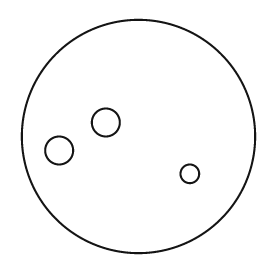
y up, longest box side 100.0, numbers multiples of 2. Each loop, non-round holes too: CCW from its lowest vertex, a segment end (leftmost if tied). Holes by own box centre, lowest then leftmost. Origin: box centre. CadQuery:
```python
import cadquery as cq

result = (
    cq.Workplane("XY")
    .moveTo(0.0, 0.0)
    .circle(50.0)
    .moveTo(22.0, -16.0)
    .circle(4.0)
    .moveTo(-34.0, -6.0)
    .circle(6.0)
    .moveTo(-14.0, 6.0)
    .circle(6.0)
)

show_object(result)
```